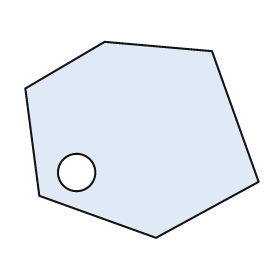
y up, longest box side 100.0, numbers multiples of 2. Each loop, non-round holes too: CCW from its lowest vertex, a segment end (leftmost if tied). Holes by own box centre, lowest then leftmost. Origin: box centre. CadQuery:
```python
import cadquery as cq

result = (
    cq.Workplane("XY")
    .moveTo(6.0, -42.0)
    .lineTo(50.0, -18.0)
    .lineTo(30.0, 38.0)
    .lineTo(-16.0, 42.0)
    .lineTo(-50.0, 22.0)
    .lineTo(-44.0, -24.0)
    .close()
    .moveTo(-28.0, -14.0)
    .circle(8.0)
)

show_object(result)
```